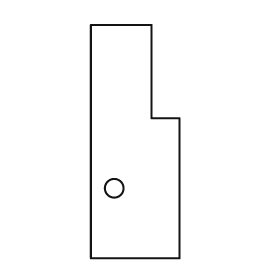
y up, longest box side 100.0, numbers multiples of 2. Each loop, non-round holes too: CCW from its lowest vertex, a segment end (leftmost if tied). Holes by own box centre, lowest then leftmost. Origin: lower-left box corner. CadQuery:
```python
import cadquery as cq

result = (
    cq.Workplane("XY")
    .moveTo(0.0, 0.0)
    .lineTo(38.0, 0.0)
    .lineTo(38.0, 60.0)
    .lineTo(26.0, 60.0)
    .lineTo(26.0, 100.0)
    .lineTo(0.0, 100.0)
    .close()
    .moveTo(10.0, 30.0)
    .circle(4.0)
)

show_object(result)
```